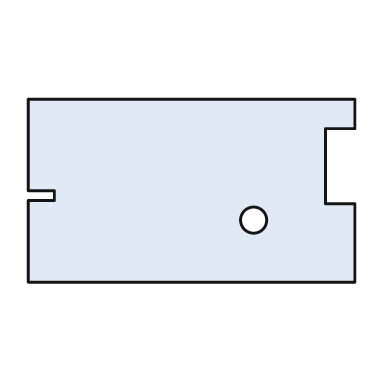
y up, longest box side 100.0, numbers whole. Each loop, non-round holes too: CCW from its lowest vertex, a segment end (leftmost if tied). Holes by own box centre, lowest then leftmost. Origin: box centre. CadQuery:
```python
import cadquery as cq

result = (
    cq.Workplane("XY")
    .moveTo(-50.0, -28.0)
    .lineTo(50.0, -28.0)
    .lineTo(50.0, -4.0)
    .lineTo(41.0, -4.0)
    .lineTo(41.0, 19.0)
    .lineTo(50.0, 19.0)
    .lineTo(50.0, 28.0)
    .lineTo(-50.0, 28.0)
    .lineTo(-50.0, 0.0)
    .lineTo(-42.0, 0.0)
    .lineTo(-42.0, -3.0)
    .lineTo(-50.0, -3.0)
    .close()
    .moveTo(19.0, -9.0)
    .circle(4.0)
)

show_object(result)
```